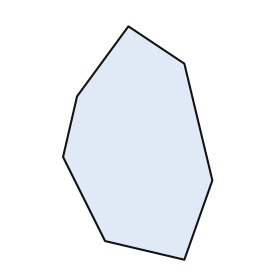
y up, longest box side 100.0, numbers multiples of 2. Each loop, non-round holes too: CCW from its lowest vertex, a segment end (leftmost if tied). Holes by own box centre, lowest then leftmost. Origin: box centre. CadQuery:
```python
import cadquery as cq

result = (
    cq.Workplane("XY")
    .moveTo(20.0, -50.0)
    .lineTo(32.0, -16.0)
    .lineTo(20.0, 34.0)
    .lineTo(-4.0, 50.0)
    .lineTo(-26.0, 20.0)
    .lineTo(-32.0, -6.0)
    .lineTo(-14.0, -42.0)
    .close()
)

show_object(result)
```